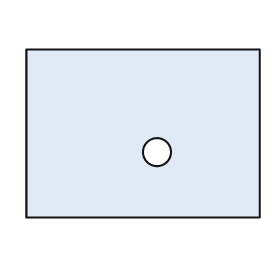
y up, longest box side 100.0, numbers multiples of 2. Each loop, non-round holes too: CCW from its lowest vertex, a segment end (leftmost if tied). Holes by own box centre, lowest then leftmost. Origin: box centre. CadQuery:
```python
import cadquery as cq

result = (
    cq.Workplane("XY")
    .moveTo(-50.0, -36.0)
    .lineTo(50.0, -36.0)
    .lineTo(50.0, 36.0)
    .lineTo(-50.0, 36.0)
    .close()
    .moveTo(6.0, -8.0)
    .circle(6.0)
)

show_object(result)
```